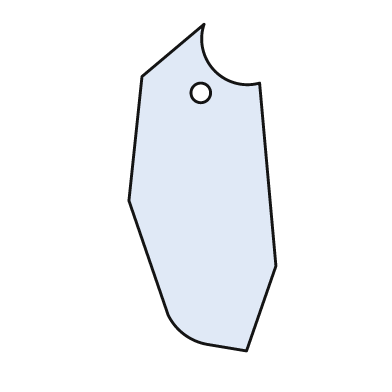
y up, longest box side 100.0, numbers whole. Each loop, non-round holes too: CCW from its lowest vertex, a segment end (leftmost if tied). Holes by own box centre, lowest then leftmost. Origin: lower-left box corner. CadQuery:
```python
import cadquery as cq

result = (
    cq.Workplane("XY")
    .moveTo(36.0, 0.0)
    .lineTo(45.0, 26.0)
    .lineTo(40.0, 82.0)
    .threePointArc((26.0, 86.0), (23.0, 100.0))
    .lineTo(4.0, 84.0)
    .lineTo(0.0, 46.0)
    .lineTo(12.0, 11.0)
    .threePointArc((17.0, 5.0), (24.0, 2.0))
    .close()
    .moveTo(22.0, 79.0)
    .circle(3.0)
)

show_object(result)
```